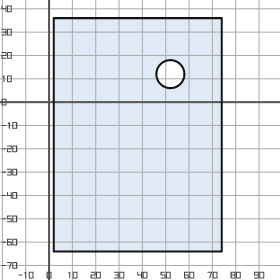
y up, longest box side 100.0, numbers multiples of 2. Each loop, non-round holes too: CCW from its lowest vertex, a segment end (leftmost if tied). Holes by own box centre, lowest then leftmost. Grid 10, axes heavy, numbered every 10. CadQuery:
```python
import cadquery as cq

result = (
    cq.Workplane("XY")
    .moveTo(2.0, -64.0)
    .lineTo(74.0, -64.0)
    .lineTo(74.0, 36.0)
    .lineTo(2.0, 36.0)
    .close()
    .moveTo(52.0, 12.0)
    .circle(6.0)
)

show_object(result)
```